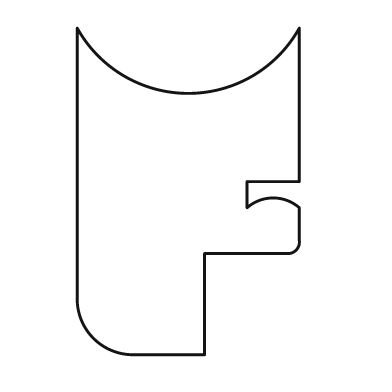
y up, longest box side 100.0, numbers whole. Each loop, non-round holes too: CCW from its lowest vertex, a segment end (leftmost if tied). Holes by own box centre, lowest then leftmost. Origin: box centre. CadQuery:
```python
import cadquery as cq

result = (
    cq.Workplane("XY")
    .moveTo(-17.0, -50.0)
    .lineTo(5.0, -50.0)
    .lineTo(5.0, -19.0)
    .lineTo(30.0, -19.0)
    .threePointArc((33.0, -18.0), (34.0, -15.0))
    .lineTo(34.0, -5.0)
    .threePointArc((26.0, -2.0), (18.0, -5.0))
    .lineTo(18.0, 3.0)
    .lineTo(34.0, 3.0)
    .lineTo(34.0, 50.0)
    .threePointArc((0.0, 30.0), (-34.0, 50.0))
    .lineTo(-34.0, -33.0)
    .threePointArc((-29.0, -45.0), (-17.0, -50.0))
    .close()
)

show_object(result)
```